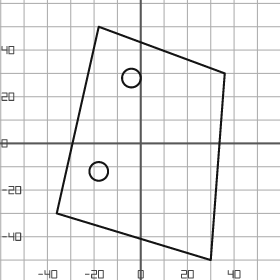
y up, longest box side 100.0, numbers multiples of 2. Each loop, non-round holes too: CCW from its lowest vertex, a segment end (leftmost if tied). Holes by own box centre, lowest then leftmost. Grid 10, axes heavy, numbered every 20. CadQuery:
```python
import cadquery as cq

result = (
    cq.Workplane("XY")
    .moveTo(30.0, -50.0)
    .lineTo(36.0, 30.0)
    .lineTo(-18.0, 50.0)
    .lineTo(-36.0, -30.0)
    .close()
    .moveTo(-18.0, -12.0)
    .circle(4.0)
    .moveTo(-4.0, 28.0)
    .circle(4.0)
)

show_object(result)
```